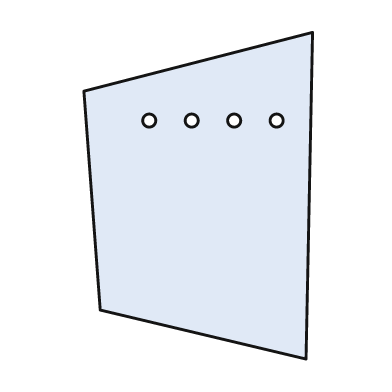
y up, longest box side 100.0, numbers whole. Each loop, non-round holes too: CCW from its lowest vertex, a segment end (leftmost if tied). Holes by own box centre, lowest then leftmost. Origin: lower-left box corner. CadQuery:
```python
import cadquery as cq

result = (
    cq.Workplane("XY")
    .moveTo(68.0, 0.0)
    .lineTo(70.0, 100.0)
    .lineTo(0.0, 82.0)
    .lineTo(5.0, 15.0)
    .close()
    .moveTo(20.0, 73.0)
    .circle(2.0)
    .moveTo(33.0, 73.0)
    .circle(2.0)
    .moveTo(46.0, 73.0)
    .circle(2.0)
    .moveTo(59.0, 73.0)
    .circle(2.0)
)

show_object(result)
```